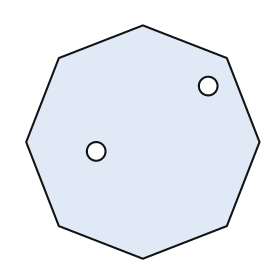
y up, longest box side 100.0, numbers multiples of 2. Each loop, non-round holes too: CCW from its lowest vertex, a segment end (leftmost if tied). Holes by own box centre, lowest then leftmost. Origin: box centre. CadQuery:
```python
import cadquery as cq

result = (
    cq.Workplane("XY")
    .moveTo(0.0, -50.0)
    .lineTo(36.0, -36.0)
    .lineTo(50.0, 0.0)
    .lineTo(36.0, 36.0)
    .lineTo(0.0, 50.0)
    .lineTo(-36.0, 36.0)
    .lineTo(-50.0, 0.0)
    .lineTo(-36.0, -36.0)
    .close()
    .moveTo(-20.0, -4.0)
    .circle(4.0)
    .moveTo(28.0, 24.0)
    .circle(4.0)
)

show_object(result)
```